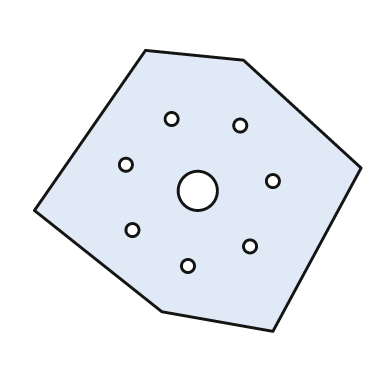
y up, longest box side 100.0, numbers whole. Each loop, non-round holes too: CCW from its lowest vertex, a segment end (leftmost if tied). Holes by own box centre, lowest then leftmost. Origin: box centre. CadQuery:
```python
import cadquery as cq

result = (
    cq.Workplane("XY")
    .moveTo(23.0, -43.0)
    .lineTo(50.0, 7.0)
    .lineTo(14.0, 40.0)
    .lineTo(-16.0, 43.0)
    .lineTo(-50.0, -6.0)
    .lineTo(-11.0, -37.0)
    .close()
    .moveTo(-3.0, -23.0)
    .circle(2.0)
    .moveTo(16.0, -17.0)
    .circle(2.0)
    .moveTo(-20.0, -12.0)
    .circle(2.0)
    .moveTo(0.0, 0.0)
    .circle(6.0)
    .moveTo(23.0, 3.0)
    .circle(2.0)
    .moveTo(-22.0, 8.0)
    .circle(2.0)
    .moveTo(13.0, 20.0)
    .circle(2.0)
    .moveTo(-8.0, 22.0)
    .circle(2.0)
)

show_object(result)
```